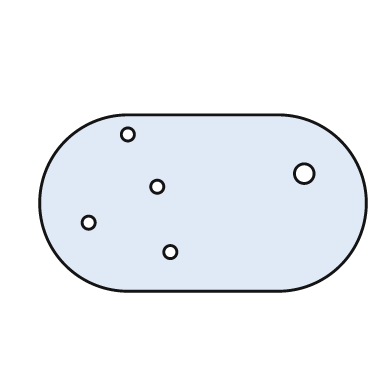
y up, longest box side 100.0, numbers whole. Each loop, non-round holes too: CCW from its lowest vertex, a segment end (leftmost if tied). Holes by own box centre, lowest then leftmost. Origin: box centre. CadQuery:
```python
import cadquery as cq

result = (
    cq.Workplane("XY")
    .moveTo(-23.0, -27.0)
    .lineTo(23.0, -27.0)
    .threePointArc((50.0, 0.0), (23.0, 27.0))
    .lineTo(-23.0, 27.0)
    .threePointArc((-50.0, 0.0), (-23.0, -27.0))
    .close()
    .moveTo(-10.0, -15.0)
    .circle(2.0)
    .moveTo(-35.0, -6.0)
    .circle(2.0)
    .moveTo(-14.0, 5.0)
    .circle(2.0)
    .moveTo(31.0, 9.0)
    .circle(3.0)
    .moveTo(-23.0, 21.0)
    .circle(2.0)
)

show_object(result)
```